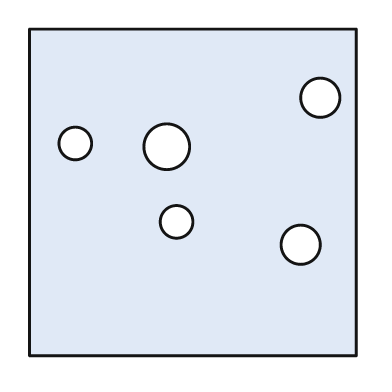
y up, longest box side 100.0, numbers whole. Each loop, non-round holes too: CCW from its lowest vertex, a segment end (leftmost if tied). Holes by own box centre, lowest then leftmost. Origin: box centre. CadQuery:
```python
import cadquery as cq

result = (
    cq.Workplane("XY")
    .moveTo(-50.0, -50.0)
    .lineTo(50.0, -50.0)
    .lineTo(50.0, 50.0)
    .lineTo(-50.0, 50.0)
    .close()
    .moveTo(33.0, -16.0)
    .circle(6.0)
    .moveTo(-5.0, -9.0)
    .circle(5.0)
    .moveTo(-8.0, 14.0)
    .circle(7.0)
    .moveTo(-36.0, 15.0)
    .circle(5.0)
    .moveTo(39.0, 29.0)
    .circle(6.0)
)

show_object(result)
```